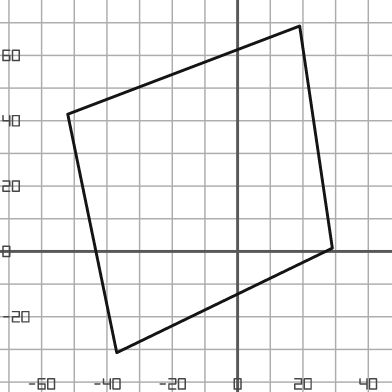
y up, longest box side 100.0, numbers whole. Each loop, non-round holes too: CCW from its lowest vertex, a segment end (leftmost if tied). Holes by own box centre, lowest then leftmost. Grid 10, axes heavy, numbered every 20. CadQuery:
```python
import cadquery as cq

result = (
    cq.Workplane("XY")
    .moveTo(-37.0, -31.0)
    .lineTo(29.0, 1.0)
    .lineTo(19.0, 69.0)
    .lineTo(-52.0, 42.0)
    .close()
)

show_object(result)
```